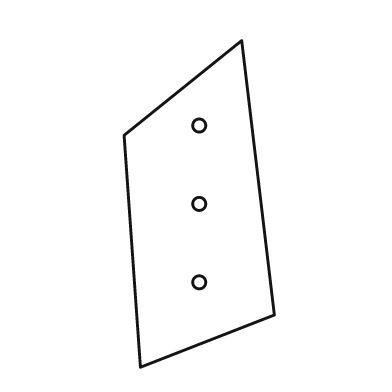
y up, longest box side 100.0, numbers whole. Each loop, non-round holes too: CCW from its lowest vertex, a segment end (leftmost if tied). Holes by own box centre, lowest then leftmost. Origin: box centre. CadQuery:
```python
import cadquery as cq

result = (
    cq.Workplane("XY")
    .moveTo(-18.0, -50.0)
    .lineTo(23.0, -34.0)
    .lineTo(13.0, 50.0)
    .lineTo(-23.0, 21.0)
    .close()
    .moveTo(0.0, -24.0)
    .circle(2.0)
    .moveTo(0.0, 0.0)
    .circle(2.0)
    .moveTo(0.0, 24.0)
    .circle(2.0)
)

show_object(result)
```